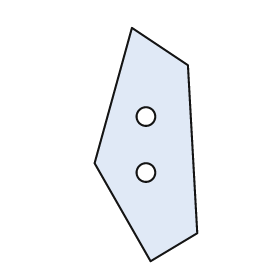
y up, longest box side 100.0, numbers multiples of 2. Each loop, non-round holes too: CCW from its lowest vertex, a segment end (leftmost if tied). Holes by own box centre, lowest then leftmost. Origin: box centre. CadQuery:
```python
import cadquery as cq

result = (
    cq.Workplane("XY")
    .moveTo(2.0, -50.0)
    .lineTo(22.0, -38.0)
    .lineTo(18.0, 34.0)
    .lineTo(-6.0, 50.0)
    .lineTo(-22.0, -8.0)
    .close()
    .moveTo(0.0, -12.0)
    .circle(4.0)
    .moveTo(0.0, 12.0)
    .circle(4.0)
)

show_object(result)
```